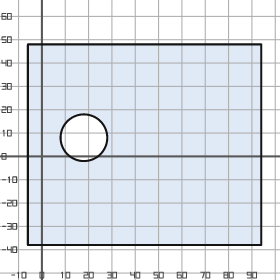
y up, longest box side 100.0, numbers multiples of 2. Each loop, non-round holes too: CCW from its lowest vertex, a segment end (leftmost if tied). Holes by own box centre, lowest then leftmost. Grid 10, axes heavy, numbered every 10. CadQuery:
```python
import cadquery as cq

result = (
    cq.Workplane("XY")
    .moveTo(-6.0, -38.0)
    .lineTo(94.0, -38.0)
    .lineTo(94.0, 48.0)
    .lineTo(-6.0, 48.0)
    .close()
    .moveTo(18.0, 8.0)
    .circle(10.0)
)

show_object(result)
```